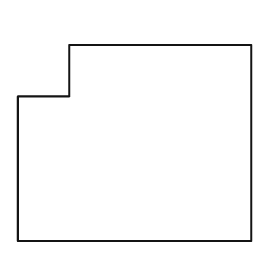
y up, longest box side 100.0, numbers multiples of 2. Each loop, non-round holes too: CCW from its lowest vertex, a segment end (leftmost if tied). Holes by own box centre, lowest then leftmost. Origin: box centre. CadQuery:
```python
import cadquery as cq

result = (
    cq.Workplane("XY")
    .moveTo(-50.0, -42.0)
    .lineTo(50.0, -42.0)
    .lineTo(50.0, 42.0)
    .lineTo(-28.0, 42.0)
    .lineTo(-28.0, 20.0)
    .lineTo(-50.0, 20.0)
    .close()
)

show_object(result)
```